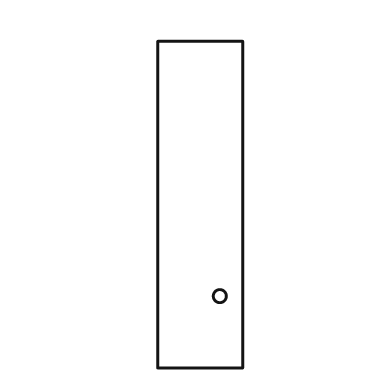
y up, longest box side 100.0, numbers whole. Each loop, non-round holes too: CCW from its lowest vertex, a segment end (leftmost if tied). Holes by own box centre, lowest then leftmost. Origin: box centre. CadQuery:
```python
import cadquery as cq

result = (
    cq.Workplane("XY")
    .moveTo(-13.0, -50.0)
    .lineTo(13.0, -50.0)
    .lineTo(13.0, 50.0)
    .lineTo(-13.0, 50.0)
    .close()
    .moveTo(6.0, -28.0)
    .circle(2.0)
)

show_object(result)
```